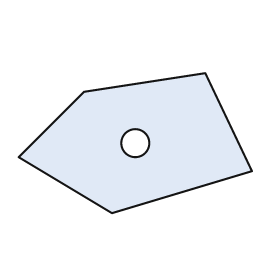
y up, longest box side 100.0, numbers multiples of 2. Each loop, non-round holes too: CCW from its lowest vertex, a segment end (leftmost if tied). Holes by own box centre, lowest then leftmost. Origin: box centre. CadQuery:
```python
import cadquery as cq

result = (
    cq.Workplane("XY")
    .moveTo(-10.0, -30.0)
    .lineTo(50.0, -12.0)
    .lineTo(30.0, 30.0)
    .lineTo(-22.0, 22.0)
    .lineTo(-50.0, -6.0)
    .close()
    .moveTo(0.0, 0.0)
    .circle(6.0)
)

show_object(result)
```